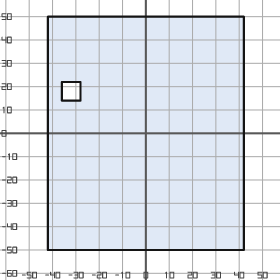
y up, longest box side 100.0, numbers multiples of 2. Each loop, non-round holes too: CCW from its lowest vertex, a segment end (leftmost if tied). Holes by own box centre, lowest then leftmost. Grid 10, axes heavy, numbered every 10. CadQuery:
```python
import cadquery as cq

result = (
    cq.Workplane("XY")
    .moveTo(-42.0, -50.0)
    .lineTo(42.0, -50.0)
    .lineTo(42.0, 50.0)
    .lineTo(-42.0, 50.0)
    .close()
    .moveTo(-36.0, 14.0)
    .lineTo(-28.0, 14.0)
    .lineTo(-28.0, 22.0)
    .lineTo(-36.0, 22.0)
    .close()
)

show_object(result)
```